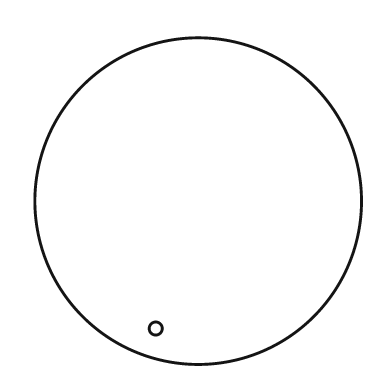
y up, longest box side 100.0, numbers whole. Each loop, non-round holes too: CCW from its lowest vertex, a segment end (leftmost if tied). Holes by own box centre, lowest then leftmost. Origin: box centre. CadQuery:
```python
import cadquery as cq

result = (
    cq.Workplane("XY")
    .moveTo(0.0, 0.0)
    .circle(50.0)
    .moveTo(-13.0, -39.0)
    .circle(2.0)
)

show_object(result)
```